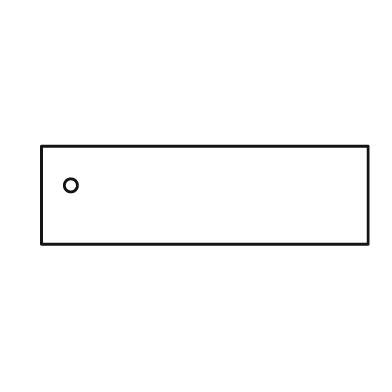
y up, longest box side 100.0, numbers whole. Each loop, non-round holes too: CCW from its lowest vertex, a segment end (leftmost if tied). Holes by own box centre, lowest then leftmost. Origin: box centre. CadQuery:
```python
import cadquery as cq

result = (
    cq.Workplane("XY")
    .moveTo(-50.0, -15.0)
    .lineTo(50.0, -15.0)
    .lineTo(50.0, 15.0)
    .lineTo(-50.0, 15.0)
    .close()
    .moveTo(-41.0, 3.0)
    .circle(2.0)
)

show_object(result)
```